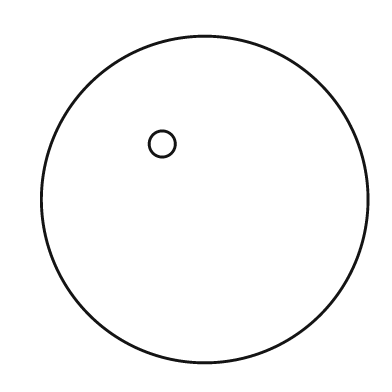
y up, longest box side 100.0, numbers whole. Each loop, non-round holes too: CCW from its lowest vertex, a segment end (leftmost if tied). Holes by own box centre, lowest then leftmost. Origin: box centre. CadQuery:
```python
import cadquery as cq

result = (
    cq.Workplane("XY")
    .moveTo(0.0, 0.0)
    .circle(50.0)
    .moveTo(-13.0, 17.0)
    .circle(4.0)
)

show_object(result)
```